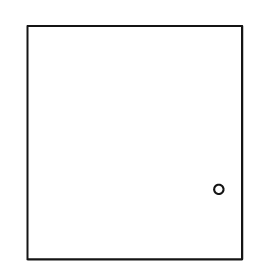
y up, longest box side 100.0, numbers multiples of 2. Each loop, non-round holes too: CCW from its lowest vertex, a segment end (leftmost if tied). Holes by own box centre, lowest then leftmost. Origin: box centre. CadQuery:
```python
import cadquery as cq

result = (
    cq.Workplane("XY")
    .moveTo(-46.0, -50.0)
    .lineTo(46.0, -50.0)
    .lineTo(46.0, 50.0)
    .lineTo(-46.0, 50.0)
    .close()
    .moveTo(36.0, -20.0)
    .circle(2.0)
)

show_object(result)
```